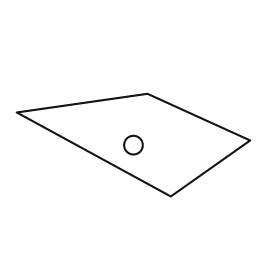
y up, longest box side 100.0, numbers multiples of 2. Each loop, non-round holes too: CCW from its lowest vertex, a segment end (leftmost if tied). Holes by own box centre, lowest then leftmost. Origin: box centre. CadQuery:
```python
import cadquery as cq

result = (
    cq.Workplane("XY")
    .moveTo(16.0, -22.0)
    .lineTo(50.0, 2.0)
    .lineTo(6.0, 22.0)
    .lineTo(-50.0, 14.0)
    .close()
    .moveTo(0.0, 0.0)
    .circle(4.0)
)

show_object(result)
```